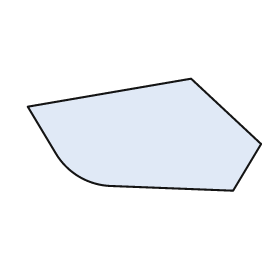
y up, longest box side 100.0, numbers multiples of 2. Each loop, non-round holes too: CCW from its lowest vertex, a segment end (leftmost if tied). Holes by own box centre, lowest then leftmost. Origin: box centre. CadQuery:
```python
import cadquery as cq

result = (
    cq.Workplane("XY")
    .moveTo(38.0, -24.0)
    .lineTo(50.0, -4.0)
    .lineTo(20.0, 24.0)
    .lineTo(-50.0, 12.0)
    .lineTo(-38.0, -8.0)
    .threePointArc((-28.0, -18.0), (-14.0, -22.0))
    .close()
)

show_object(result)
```